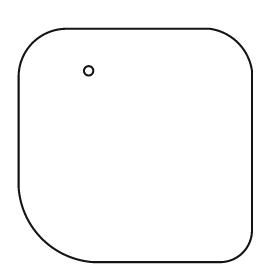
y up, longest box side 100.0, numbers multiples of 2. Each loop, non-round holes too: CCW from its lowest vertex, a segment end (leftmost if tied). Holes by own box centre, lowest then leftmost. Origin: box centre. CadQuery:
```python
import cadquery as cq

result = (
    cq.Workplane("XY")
    .moveTo(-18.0, -50.0)
    .lineTo(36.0, -50.0)
    .threePointArc((46.0, -46.0), (50.0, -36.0))
    .lineTo(50.0, 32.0)
    .threePointArc((44.0, 44.0), (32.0, 50.0))
    .lineTo(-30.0, 50.0)
    .threePointArc((-44.0, 44.0), (-50.0, 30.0))
    .lineTo(-50.0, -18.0)
    .threePointArc((-40.0, -40.0), (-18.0, -50.0))
    .close()
    .moveTo(-20.0, 32.0)
    .circle(2.0)
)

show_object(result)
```